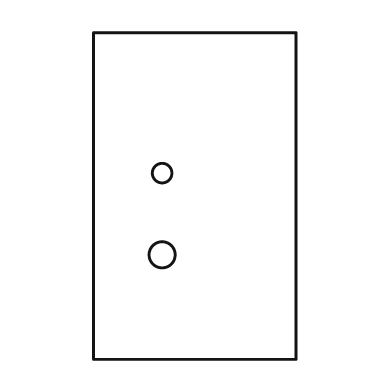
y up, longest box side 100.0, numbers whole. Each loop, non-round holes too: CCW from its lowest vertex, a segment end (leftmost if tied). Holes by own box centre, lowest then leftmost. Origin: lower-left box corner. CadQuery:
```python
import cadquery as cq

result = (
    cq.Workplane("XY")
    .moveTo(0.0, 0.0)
    .lineTo(62.0, 0.0)
    .lineTo(62.0, 100.0)
    .lineTo(0.0, 100.0)
    .close()
    .moveTo(21.0, 32.0)
    .circle(4.0)
    .moveTo(21.0, 57.0)
    .circle(3.0)
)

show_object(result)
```